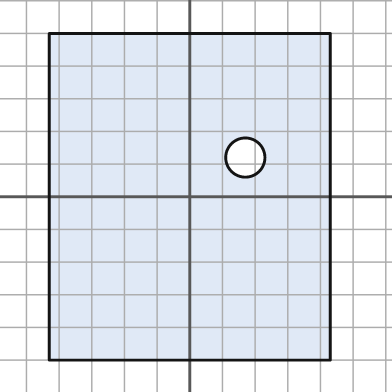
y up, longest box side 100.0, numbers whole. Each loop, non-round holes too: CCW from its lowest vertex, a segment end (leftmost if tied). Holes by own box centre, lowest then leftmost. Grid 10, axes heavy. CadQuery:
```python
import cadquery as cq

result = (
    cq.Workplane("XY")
    .moveTo(-43.0, -50.0)
    .lineTo(43.0, -50.0)
    .lineTo(43.0, 50.0)
    .lineTo(-43.0, 50.0)
    .close()
    .moveTo(17.0, 12.0)
    .circle(6.0)
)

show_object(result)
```